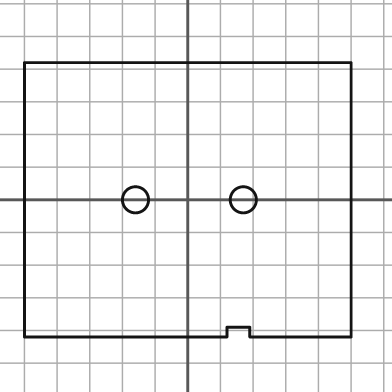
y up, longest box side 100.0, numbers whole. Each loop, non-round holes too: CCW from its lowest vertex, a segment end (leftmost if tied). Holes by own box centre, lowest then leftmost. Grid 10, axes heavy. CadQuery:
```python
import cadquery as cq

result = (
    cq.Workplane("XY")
    .moveTo(-50.0, -42.0)
    .lineTo(12.0, -42.0)
    .lineTo(12.0, -39.0)
    .lineTo(19.0, -39.0)
    .lineTo(19.0, -42.0)
    .lineTo(50.0, -42.0)
    .lineTo(50.0, 42.0)
    .lineTo(-50.0, 42.0)
    .close()
    .moveTo(-16.0, 0.0)
    .circle(4.0)
    .moveTo(17.0, 0.0)
    .circle(4.0)
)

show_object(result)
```